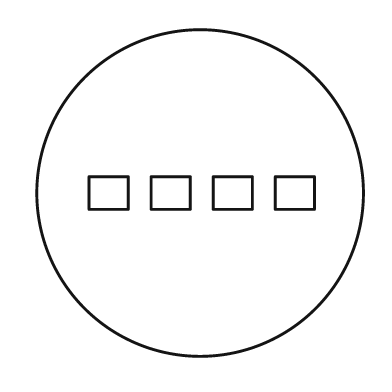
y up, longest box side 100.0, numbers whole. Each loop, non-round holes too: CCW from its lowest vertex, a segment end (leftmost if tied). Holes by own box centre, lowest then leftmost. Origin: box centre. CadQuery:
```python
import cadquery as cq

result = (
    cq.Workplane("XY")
    .moveTo(0.0, 0.0)
    .circle(50.0)
    .moveTo(-34.0, -5.0)
    .lineTo(-22.0, -5.0)
    .lineTo(-22.0, 5.0)
    .lineTo(-34.0, 5.0)
    .close()
    .moveTo(-15.0, -5.0)
    .lineTo(-3.0, -5.0)
    .lineTo(-3.0, 5.0)
    .lineTo(-15.0, 5.0)
    .close()
    .moveTo(4.0, -5.0)
    .lineTo(16.0, -5.0)
    .lineTo(16.0, 5.0)
    .lineTo(4.0, 5.0)
    .close()
    .moveTo(23.0, -5.0)
    .lineTo(35.0, -5.0)
    .lineTo(35.0, 5.0)
    .lineTo(23.0, 5.0)
    .close()
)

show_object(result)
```